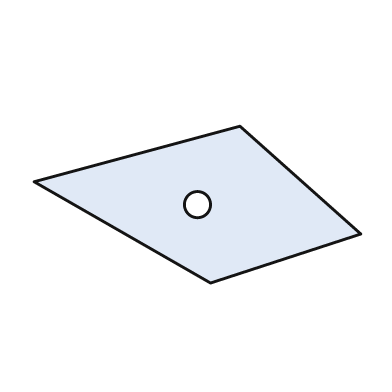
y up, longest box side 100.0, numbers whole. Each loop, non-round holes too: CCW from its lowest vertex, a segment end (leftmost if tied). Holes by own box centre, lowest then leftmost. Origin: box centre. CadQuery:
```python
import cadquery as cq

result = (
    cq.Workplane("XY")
    .moveTo(4.0, -24.0)
    .lineTo(50.0, -9.0)
    .lineTo(13.0, 24.0)
    .lineTo(-50.0, 7.0)
    .close()
    .moveTo(0.0, 0.0)
    .circle(4.0)
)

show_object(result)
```